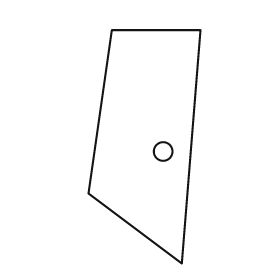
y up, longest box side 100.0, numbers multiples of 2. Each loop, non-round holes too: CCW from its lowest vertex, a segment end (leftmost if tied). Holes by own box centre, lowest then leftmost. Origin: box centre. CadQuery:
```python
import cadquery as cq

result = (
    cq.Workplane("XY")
    .moveTo(16.0, -50.0)
    .lineTo(24.0, 50.0)
    .lineTo(-14.0, 50.0)
    .lineTo(-24.0, -20.0)
    .close()
    .moveTo(8.0, -2.0)
    .circle(4.0)
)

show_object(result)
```